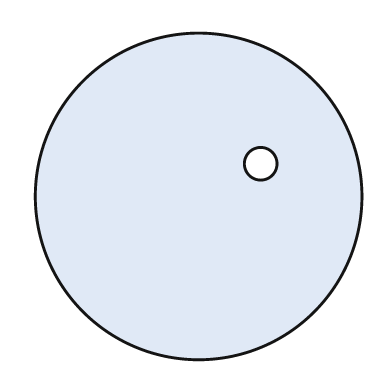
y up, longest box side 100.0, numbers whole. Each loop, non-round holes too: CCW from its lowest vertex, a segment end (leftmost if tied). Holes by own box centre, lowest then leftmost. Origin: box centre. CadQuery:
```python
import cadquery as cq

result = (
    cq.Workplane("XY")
    .moveTo(0.0, 0.0)
    .circle(50.0)
    .moveTo(19.0, 10.0)
    .circle(5.0)
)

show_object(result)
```